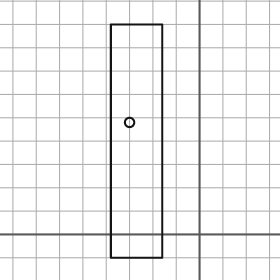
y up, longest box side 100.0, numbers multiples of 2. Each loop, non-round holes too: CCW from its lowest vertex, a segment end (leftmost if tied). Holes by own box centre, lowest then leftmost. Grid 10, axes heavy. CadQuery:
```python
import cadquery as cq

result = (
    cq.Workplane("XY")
    .moveTo(-38.0, -10.0)
    .lineTo(-16.0, -10.0)
    .lineTo(-16.0, 90.0)
    .lineTo(-38.0, 90.0)
    .close()
    .moveTo(-30.0, 48.0)
    .circle(2.0)
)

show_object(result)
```